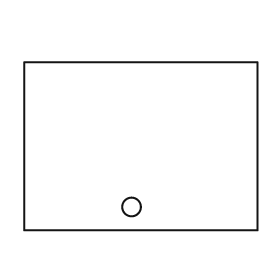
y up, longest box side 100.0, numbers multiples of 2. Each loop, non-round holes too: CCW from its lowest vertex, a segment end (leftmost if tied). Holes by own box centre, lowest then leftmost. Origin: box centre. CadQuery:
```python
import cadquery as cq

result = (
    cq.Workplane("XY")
    .moveTo(-50.0, -36.0)
    .lineTo(50.0, -36.0)
    .lineTo(50.0, 36.0)
    .lineTo(-50.0, 36.0)
    .close()
    .moveTo(-4.0, -26.0)
    .circle(4.0)
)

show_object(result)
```